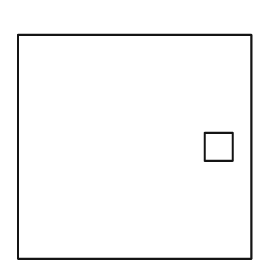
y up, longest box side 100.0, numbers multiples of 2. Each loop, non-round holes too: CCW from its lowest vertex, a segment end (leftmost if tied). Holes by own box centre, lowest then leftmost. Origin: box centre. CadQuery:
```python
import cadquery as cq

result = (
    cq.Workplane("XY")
    .moveTo(-50.0, -48.0)
    .lineTo(50.0, -48.0)
    .lineTo(50.0, 48.0)
    .lineTo(-50.0, 48.0)
    .close()
    .moveTo(30.0, -6.0)
    .lineTo(42.0, -6.0)
    .lineTo(42.0, 6.0)
    .lineTo(30.0, 6.0)
    .close()
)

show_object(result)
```